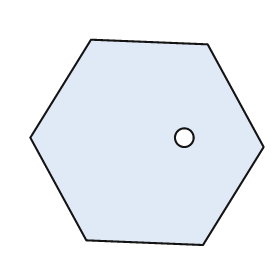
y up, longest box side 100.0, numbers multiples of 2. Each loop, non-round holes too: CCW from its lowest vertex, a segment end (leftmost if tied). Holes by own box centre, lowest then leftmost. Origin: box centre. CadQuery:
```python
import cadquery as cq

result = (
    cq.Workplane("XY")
    .moveTo(24.0, -44.0)
    .lineTo(50.0, -2.0)
    .lineTo(26.0, 42.0)
    .lineTo(-24.0, 44.0)
    .lineTo(-50.0, 2.0)
    .lineTo(-26.0, -42.0)
    .close()
    .moveTo(16.0, 2.0)
    .circle(4.0)
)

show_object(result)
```